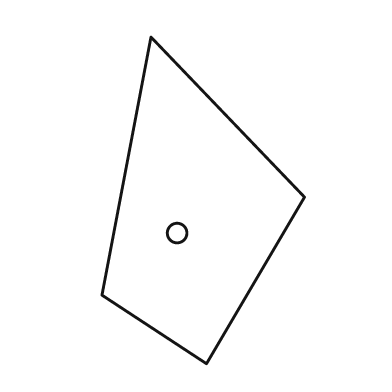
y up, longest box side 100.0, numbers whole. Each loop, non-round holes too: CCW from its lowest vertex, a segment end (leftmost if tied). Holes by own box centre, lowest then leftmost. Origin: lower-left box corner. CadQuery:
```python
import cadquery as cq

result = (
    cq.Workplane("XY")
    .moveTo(32.0, 0.0)
    .lineTo(62.0, 51.0)
    .lineTo(15.0, 100.0)
    .lineTo(0.0, 21.0)
    .close()
    .moveTo(23.0, 40.0)
    .circle(3.0)
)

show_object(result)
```